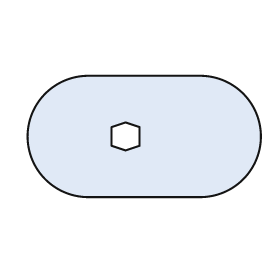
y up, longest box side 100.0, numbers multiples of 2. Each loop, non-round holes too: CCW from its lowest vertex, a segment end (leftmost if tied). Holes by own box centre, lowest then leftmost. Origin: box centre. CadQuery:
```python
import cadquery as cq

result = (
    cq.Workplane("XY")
    .moveTo(-24.0, -26.0)
    .lineTo(24.0, -26.0)
    .threePointArc((50.0, 0.0), (24.0, 26.0))
    .lineTo(-24.0, 26.0)
    .threePointArc((-50.0, 0.0), (-24.0, -26.0))
    .close()
    .moveTo(-8.0, -6.0)
    .lineTo(-2.0, -4.0)
    .lineTo(-2.0, 4.0)
    .lineTo(-8.0, 6.0)
    .lineTo(-14.0, 4.0)
    .lineTo(-14.0, -4.0)
    .close()
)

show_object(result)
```